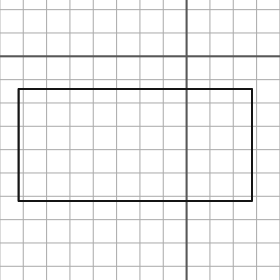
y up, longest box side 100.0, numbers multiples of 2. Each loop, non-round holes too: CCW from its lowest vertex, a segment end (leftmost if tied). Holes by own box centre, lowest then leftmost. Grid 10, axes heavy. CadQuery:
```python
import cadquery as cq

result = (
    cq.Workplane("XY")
    .moveTo(-72.0, -62.0)
    .lineTo(28.0, -62.0)
    .lineTo(28.0, -14.0)
    .lineTo(-72.0, -14.0)
    .close()
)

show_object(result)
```